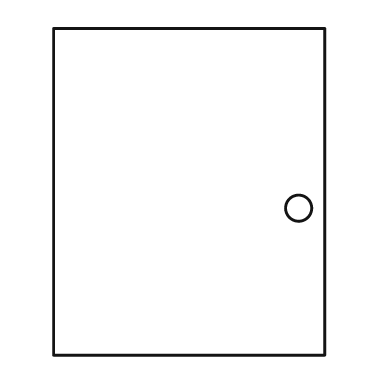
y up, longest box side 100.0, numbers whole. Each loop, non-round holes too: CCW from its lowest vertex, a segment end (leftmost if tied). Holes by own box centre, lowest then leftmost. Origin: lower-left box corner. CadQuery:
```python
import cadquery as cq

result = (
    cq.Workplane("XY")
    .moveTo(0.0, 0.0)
    .lineTo(83.0, 0.0)
    .lineTo(83.0, 100.0)
    .lineTo(0.0, 100.0)
    .close()
    .moveTo(75.0, 45.0)
    .circle(4.0)
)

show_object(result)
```